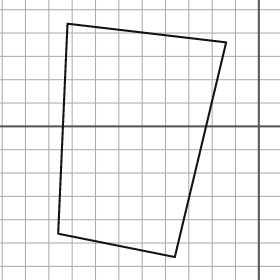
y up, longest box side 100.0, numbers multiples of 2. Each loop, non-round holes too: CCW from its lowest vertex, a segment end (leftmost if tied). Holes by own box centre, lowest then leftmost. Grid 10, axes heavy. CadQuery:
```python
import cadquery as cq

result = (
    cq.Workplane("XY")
    .moveTo(-36.0, -56.0)
    .lineTo(-14.0, 36.0)
    .lineTo(-82.0, 44.0)
    .lineTo(-86.0, -46.0)
    .close()
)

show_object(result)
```